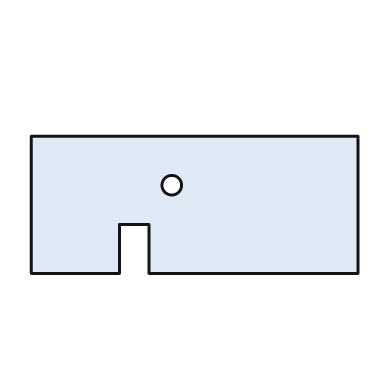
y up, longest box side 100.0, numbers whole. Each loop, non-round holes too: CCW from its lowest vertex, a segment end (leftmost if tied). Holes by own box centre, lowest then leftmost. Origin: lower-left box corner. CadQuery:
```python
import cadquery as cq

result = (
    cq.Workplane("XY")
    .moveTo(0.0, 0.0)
    .lineTo(27.0, 0.0)
    .lineTo(27.0, 15.0)
    .lineTo(36.0, 15.0)
    .lineTo(36.0, 0.0)
    .lineTo(100.0, 0.0)
    .lineTo(100.0, 42.0)
    .lineTo(0.0, 42.0)
    .close()
    .moveTo(43.0, 27.0)
    .circle(3.0)
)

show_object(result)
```